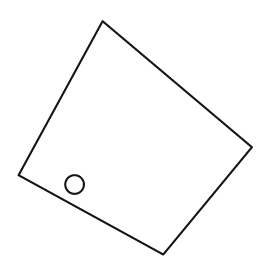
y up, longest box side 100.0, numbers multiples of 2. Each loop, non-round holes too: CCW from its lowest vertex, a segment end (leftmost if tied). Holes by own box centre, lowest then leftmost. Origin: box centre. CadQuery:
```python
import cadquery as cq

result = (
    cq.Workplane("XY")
    .moveTo(12.0, -50.0)
    .lineTo(50.0, -4.0)
    .lineTo(-14.0, 50.0)
    .lineTo(-50.0, -16.0)
    .close()
    .moveTo(-26.0, -20.0)
    .circle(4.0)
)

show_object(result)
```